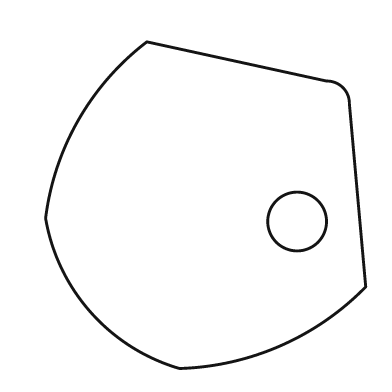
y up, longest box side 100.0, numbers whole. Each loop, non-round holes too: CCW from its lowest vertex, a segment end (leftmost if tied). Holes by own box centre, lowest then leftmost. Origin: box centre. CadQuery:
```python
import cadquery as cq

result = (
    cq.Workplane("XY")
    .moveTo(-8.0, -50.0)
    .threePointArc((23.0, -43.0), (49.0, -25.0))
    .lineTo(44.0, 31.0)
    .threePointArc((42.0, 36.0), (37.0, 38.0))
    .lineTo(-18.0, 50.0)
    .threePointArc((-39.0, 26.0), (-49.0, -4.0))
    .threePointArc((-35.0, -33.0), (-8.0, -50.0))
    .close()
    .moveTo(28.0, -5.0)
    .circle(9.0)
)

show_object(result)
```